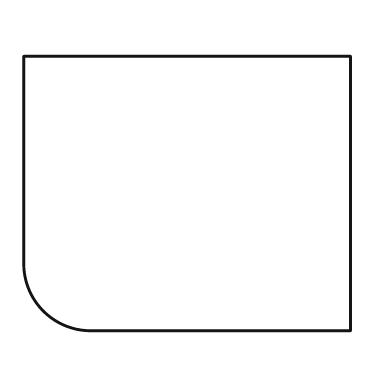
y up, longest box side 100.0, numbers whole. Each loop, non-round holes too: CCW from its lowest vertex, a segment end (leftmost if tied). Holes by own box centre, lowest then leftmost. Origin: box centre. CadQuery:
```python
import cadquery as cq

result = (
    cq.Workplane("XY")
    .moveTo(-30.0, -42.0)
    .lineTo(50.0, -42.0)
    .lineTo(50.0, 42.0)
    .lineTo(-50.0, 42.0)
    .lineTo(-50.0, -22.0)
    .threePointArc((-44.0, -36.0), (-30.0, -42.0))
    .close()
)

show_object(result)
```